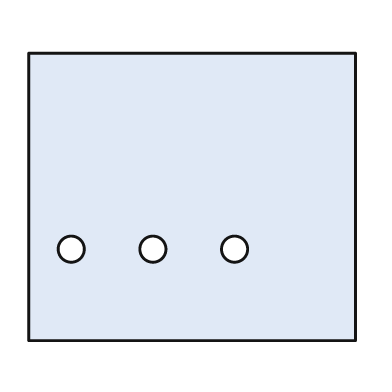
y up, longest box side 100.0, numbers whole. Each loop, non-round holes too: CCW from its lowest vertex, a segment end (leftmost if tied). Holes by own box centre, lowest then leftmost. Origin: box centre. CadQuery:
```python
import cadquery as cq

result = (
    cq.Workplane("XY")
    .moveTo(-50.0, -44.0)
    .lineTo(50.0, -44.0)
    .lineTo(50.0, 44.0)
    .lineTo(-50.0, 44.0)
    .close()
    .moveTo(-37.0, -16.0)
    .circle(4.0)
    .moveTo(-12.0, -16.0)
    .circle(4.0)
    .moveTo(13.0, -16.0)
    .circle(4.0)
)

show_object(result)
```